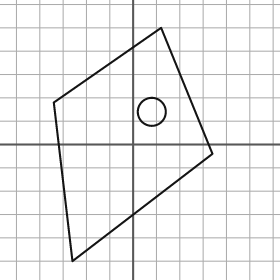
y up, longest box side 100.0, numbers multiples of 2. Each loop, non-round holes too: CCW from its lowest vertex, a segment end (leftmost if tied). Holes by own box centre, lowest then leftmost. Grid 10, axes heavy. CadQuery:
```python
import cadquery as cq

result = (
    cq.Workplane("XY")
    .moveTo(-26.0, -50.0)
    .lineTo(34.0, -4.0)
    .lineTo(12.0, 50.0)
    .lineTo(-34.0, 18.0)
    .close()
    .moveTo(8.0, 14.0)
    .circle(6.0)
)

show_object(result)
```